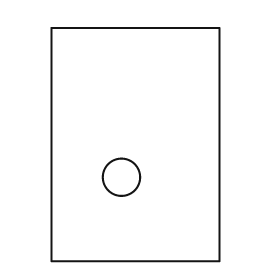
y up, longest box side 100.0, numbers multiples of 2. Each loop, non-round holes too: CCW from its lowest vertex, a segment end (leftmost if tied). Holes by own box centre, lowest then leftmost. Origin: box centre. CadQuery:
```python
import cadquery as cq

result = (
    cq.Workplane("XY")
    .moveTo(-36.0, -50.0)
    .lineTo(36.0, -50.0)
    .lineTo(36.0, 50.0)
    .lineTo(-36.0, 50.0)
    .close()
    .moveTo(-6.0, -14.0)
    .circle(8.0)
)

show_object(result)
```